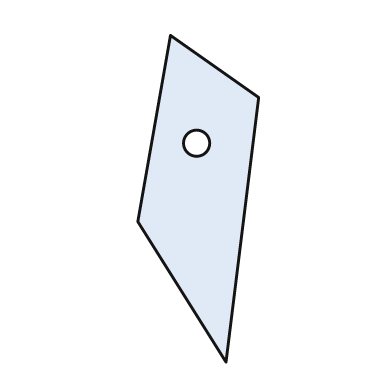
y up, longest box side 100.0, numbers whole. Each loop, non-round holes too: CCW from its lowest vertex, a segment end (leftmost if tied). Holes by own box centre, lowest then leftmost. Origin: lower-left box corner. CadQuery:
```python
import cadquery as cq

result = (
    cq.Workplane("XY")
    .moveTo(27.0, 0.0)
    .lineTo(37.0, 81.0)
    .lineTo(10.0, 100.0)
    .lineTo(0.0, 43.0)
    .close()
    .moveTo(18.0, 67.0)
    .circle(4.0)
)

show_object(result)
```